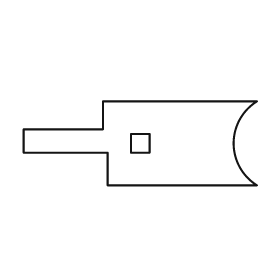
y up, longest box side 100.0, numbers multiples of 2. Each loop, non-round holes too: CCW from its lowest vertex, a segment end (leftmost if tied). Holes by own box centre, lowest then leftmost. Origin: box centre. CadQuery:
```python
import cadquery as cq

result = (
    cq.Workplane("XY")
    .moveTo(-14.0, -18.0)
    .lineTo(50.0, -18.0)
    .threePointArc((40.0, 0.0), (50.0, 18.0))
    .lineTo(-16.0, 18.0)
    .lineTo(-16.0, 6.0)
    .lineTo(-50.0, 6.0)
    .lineTo(-50.0, -4.0)
    .lineTo(-14.0, -4.0)
    .close()
    .moveTo(-4.0, -4.0)
    .lineTo(4.0, -4.0)
    .lineTo(4.0, 4.0)
    .lineTo(-4.0, 4.0)
    .close()
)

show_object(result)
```